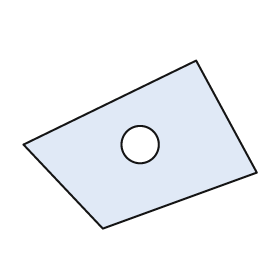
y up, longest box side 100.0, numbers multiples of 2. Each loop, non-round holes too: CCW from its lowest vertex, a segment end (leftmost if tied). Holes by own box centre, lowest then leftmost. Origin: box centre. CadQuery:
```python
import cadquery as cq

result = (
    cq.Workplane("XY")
    .moveTo(-16.0, -36.0)
    .lineTo(50.0, -12.0)
    .lineTo(24.0, 36.0)
    .lineTo(-50.0, 0.0)
    .close()
    .moveTo(0.0, 0.0)
    .circle(8.0)
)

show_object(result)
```